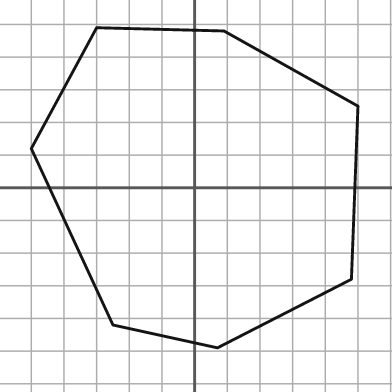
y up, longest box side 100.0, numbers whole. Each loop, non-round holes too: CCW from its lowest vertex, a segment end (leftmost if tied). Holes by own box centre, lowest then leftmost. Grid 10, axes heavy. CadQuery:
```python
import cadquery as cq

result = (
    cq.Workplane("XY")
    .moveTo(7.0, -49.0)
    .lineTo(48.0, -28.0)
    .lineTo(50.0, 25.0)
    .lineTo(9.0, 48.0)
    .lineTo(-30.0, 49.0)
    .lineTo(-50.0, 12.0)
    .lineTo(-25.0, -42.0)
    .close()
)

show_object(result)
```